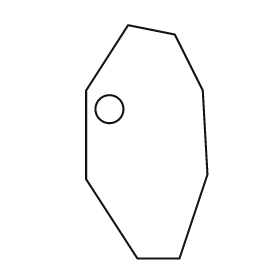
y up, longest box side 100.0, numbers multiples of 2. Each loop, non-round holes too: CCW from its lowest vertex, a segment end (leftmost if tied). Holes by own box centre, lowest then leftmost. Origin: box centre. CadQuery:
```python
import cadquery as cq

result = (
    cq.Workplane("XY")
    .moveTo(-4.0, -50.0)
    .lineTo(14.0, -50.0)
    .lineTo(26.0, -14.0)
    .lineTo(24.0, 22.0)
    .lineTo(12.0, 46.0)
    .lineTo(-8.0, 50.0)
    .lineTo(-26.0, 22.0)
    .lineTo(-26.0, -16.0)
    .close()
    .moveTo(-16.0, 14.0)
    .circle(6.0)
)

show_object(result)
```